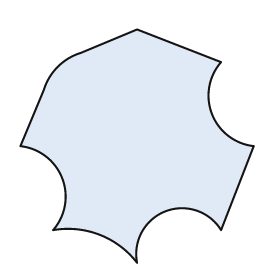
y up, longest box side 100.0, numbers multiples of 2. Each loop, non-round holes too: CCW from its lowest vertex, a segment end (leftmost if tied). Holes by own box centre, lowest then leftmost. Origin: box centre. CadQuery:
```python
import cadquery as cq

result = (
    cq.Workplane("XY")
    .moveTo(0.0, -50.0)
    .threePointArc((12.0, -28.0), (36.0, -36.0))
    .lineTo(50.0, 0.0)
    .threePointArc((32.0, 14.0), (36.0, 36.0))
    .lineTo(0.0, 50.0)
    .lineTo(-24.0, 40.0)
    .threePointArc((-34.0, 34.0), (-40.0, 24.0))
    .lineTo(-50.0, 0.0)
    .threePointArc((-32.0, -14.0), (-36.0, -36.0))
    .threePointArc((-16.0, -38.0), (0.0, -50.0))
    .close()
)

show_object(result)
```